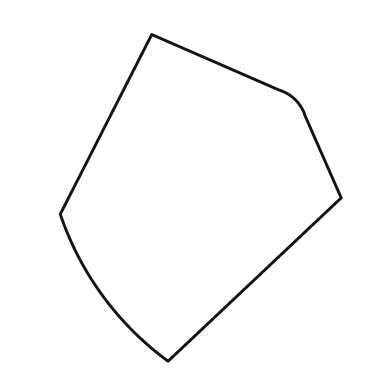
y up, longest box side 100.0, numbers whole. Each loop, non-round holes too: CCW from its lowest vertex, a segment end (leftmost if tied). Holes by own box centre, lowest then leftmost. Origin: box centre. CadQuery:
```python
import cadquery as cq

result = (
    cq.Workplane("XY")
    .moveTo(-10.0, -50.0)
    .lineTo(43.0, 0.0)
    .lineTo(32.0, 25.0)
    .threePointArc((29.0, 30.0), (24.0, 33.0))
    .lineTo(-15.0, 50.0)
    .lineTo(-43.0, -5.0)
    .threePointArc((-30.0, -30.0), (-10.0, -50.0))
    .close()
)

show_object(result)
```